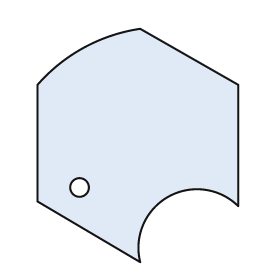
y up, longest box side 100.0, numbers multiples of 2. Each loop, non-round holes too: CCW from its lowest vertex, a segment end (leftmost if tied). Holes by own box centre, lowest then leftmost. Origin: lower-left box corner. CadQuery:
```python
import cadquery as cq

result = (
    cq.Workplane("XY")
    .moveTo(44.0, 0.0)
    .threePointArc((56.0, 28.0), (86.0, 24.0))
    .lineTo(86.0, 76.0)
    .lineTo(44.0, 100.0)
    .threePointArc((20.0, 92.0), (0.0, 76.0))
    .lineTo(0.0, 26.0)
    .close()
    .moveTo(18.0, 32.0)
    .circle(4.0)
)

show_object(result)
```